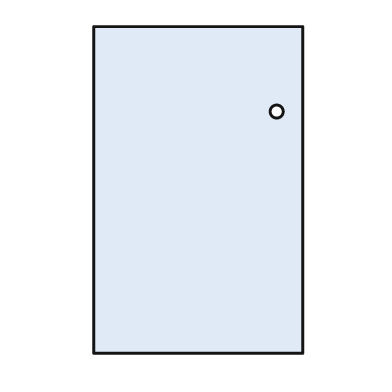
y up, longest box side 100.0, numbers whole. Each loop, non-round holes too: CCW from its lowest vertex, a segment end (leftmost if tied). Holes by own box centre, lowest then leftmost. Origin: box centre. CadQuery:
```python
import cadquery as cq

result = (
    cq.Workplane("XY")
    .moveTo(-32.0, -50.0)
    .lineTo(32.0, -50.0)
    .lineTo(32.0, 50.0)
    .lineTo(-32.0, 50.0)
    .close()
    .moveTo(24.0, 24.0)
    .circle(2.0)
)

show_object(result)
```